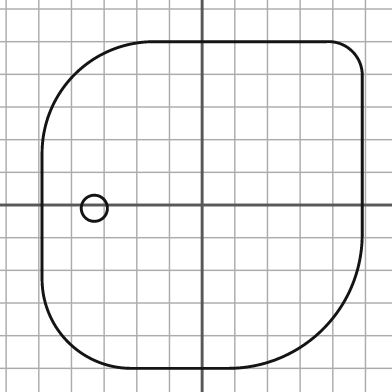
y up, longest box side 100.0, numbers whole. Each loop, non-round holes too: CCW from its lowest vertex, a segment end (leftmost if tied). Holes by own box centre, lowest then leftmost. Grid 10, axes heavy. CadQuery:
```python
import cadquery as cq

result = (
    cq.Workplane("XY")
    .moveTo(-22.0, -50.0)
    .lineTo(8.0, -50.0)
    .threePointArc((37.0, -38.0), (49.0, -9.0))
    .lineTo(49.0, 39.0)
    .threePointArc((46.0, 47.0), (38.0, 50.0))
    .lineTo(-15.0, 50.0)
    .threePointArc((-39.0, 40.0), (-49.0, 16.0))
    .lineTo(-49.0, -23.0)
    .threePointArc((-41.0, -42.0), (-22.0, -50.0))
    .close()
    .moveTo(-33.0, -1.0)
    .circle(4.0)
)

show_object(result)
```